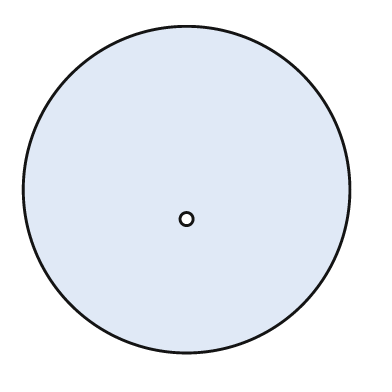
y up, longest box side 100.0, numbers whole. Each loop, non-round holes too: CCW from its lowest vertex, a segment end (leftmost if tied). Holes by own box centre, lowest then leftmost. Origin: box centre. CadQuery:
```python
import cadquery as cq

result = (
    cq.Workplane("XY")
    .moveTo(0.0, 0.0)
    .circle(50.0)
    .moveTo(0.0, -9.0)
    .circle(2.0)
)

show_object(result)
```